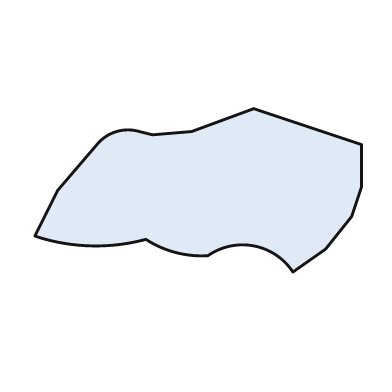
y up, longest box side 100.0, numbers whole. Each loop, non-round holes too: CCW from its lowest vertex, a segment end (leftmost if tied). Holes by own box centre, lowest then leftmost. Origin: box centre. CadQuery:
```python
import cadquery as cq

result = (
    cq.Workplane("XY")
    .moveTo(29.0, -25.0)
    .lineTo(39.0, -18.0)
    .lineTo(47.0, -8.0)
    .lineTo(50.0, 1.0)
    .lineTo(50.0, 14.0)
    .lineTo(17.0, 25.0)
    .lineTo(-2.0, 18.0)
    .lineTo(-14.0, 17.0)
    .lineTo(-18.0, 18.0)
    .threePointArc((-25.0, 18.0), (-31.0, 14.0))
    .lineTo(-43.0, 0.0)
    .lineTo(-50.0, -14.0)
    .threePointArc((-33.0, -17.0), (-16.0, -15.0))
    .threePointArc((-7.0, -19.0), (3.0, -20.0))
    .threePointArc((17.0, -17.0), (29.0, -25.0))
    .close()
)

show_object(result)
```